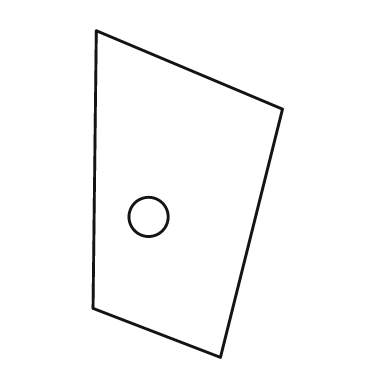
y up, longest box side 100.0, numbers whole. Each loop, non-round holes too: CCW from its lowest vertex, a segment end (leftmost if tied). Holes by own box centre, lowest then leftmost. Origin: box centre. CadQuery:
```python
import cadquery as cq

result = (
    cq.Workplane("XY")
    .moveTo(10.0, -50.0)
    .lineTo(29.0, 26.0)
    .lineTo(-28.0, 50.0)
    .lineTo(-29.0, -35.0)
    .close()
    .moveTo(-12.0, -7.0)
    .circle(6.0)
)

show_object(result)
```